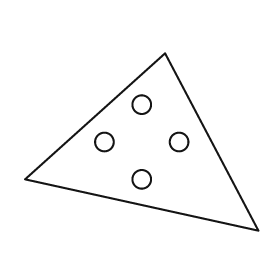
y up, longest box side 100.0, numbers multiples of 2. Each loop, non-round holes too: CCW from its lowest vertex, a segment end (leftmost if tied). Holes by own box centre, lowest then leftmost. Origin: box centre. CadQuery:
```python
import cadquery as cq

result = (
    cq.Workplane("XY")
    .moveTo(50.0, -38.0)
    .lineTo(10.0, 38.0)
    .lineTo(-50.0, -16.0)
    .close()
    .moveTo(0.0, -16.0)
    .circle(4.0)
    .moveTo(-16.0, 0.0)
    .circle(4.0)
    .moveTo(16.0, 0.0)
    .circle(4.0)
    .moveTo(0.0, 16.0)
    .circle(4.0)
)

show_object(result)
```